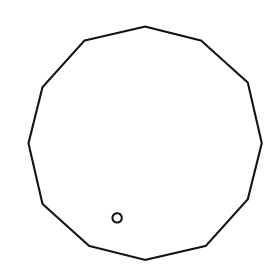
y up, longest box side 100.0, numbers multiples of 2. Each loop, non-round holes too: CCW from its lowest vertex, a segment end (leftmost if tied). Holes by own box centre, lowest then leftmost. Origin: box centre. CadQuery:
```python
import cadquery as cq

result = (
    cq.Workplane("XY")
    .moveTo(0.0, -50.0)
    .lineTo(26.0, -44.0)
    .lineTo(44.0, -24.0)
    .lineTo(50.0, 0.0)
    .lineTo(44.0, 26.0)
    .lineTo(24.0, 44.0)
    .lineTo(0.0, 50.0)
    .lineTo(-26.0, 44.0)
    .lineTo(-44.0, 24.0)
    .lineTo(-50.0, 0.0)
    .lineTo(-44.0, -26.0)
    .lineTo(-24.0, -44.0)
    .close()
    .moveTo(-12.0, -32.0)
    .circle(2.0)
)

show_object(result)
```